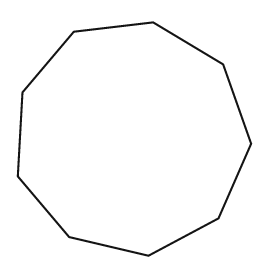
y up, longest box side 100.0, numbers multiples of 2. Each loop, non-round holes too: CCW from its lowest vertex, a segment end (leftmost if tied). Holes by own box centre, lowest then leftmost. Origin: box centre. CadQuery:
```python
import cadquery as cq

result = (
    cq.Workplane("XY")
    .moveTo(6.0, -50.0)
    .lineTo(36.0, -34.0)
    .lineTo(50.0, -2.0)
    .lineTo(38.0, 32.0)
    .lineTo(8.0, 50.0)
    .lineTo(-26.0, 46.0)
    .lineTo(-48.0, 20.0)
    .lineTo(-50.0, -16.0)
    .lineTo(-28.0, -42.0)
    .close()
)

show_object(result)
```